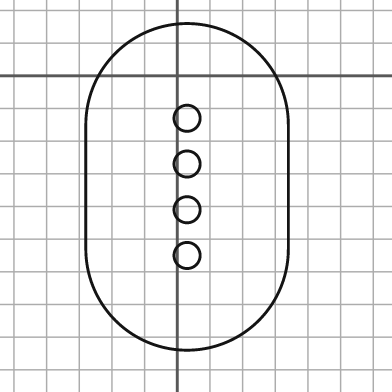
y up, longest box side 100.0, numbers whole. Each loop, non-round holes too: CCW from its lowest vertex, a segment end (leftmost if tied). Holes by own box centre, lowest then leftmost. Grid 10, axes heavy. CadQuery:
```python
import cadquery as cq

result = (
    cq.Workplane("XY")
    .moveTo(-28.0, -53.0)
    .threePointArc((3.0, -84.0), (34.0, -53.0))
    .lineTo(34.0, -15.0)
    .threePointArc((3.0, 16.0), (-28.0, -15.0))
    .close()
    .moveTo(3.0, -55.0)
    .circle(4.0)
    .moveTo(3.0, -41.0)
    .circle(4.0)
    .moveTo(3.0, -27.0)
    .circle(4.0)
    .moveTo(3.0, -13.0)
    .circle(4.0)
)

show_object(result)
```